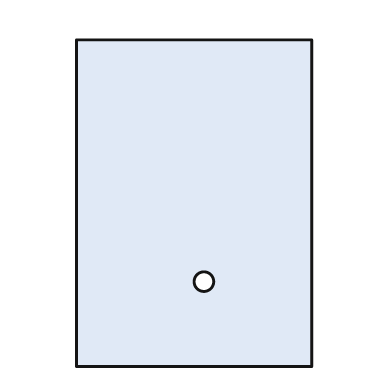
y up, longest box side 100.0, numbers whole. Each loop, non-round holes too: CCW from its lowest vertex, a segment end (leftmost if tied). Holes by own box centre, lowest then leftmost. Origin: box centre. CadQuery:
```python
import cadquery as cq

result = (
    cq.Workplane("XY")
    .moveTo(-36.0, -50.0)
    .lineTo(36.0, -50.0)
    .lineTo(36.0, 50.0)
    .lineTo(-36.0, 50.0)
    .close()
    .moveTo(3.0, -24.0)
    .circle(3.0)
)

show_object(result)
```